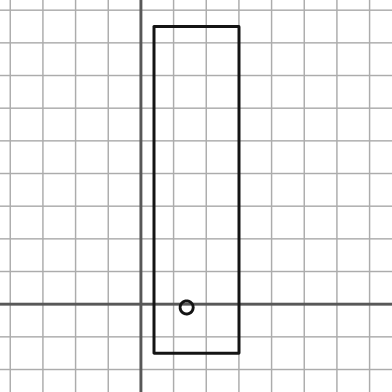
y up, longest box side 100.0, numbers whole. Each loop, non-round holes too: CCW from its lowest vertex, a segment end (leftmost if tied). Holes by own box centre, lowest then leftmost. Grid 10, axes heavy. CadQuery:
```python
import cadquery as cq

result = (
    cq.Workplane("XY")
    .moveTo(4.0, -15.0)
    .lineTo(30.0, -15.0)
    .lineTo(30.0, 85.0)
    .lineTo(4.0, 85.0)
    .close()
    .moveTo(14.0, -1.0)
    .circle(2.0)
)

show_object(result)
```